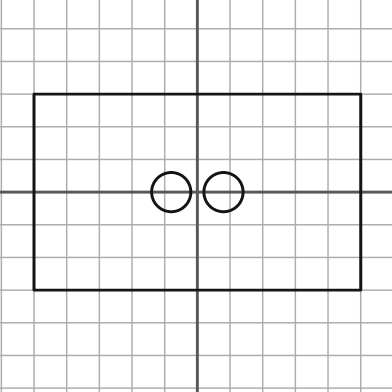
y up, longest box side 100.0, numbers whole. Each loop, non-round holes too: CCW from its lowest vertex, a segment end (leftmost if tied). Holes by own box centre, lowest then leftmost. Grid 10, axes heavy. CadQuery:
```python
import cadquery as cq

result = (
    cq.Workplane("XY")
    .moveTo(-50.0, -30.0)
    .lineTo(50.0, -30.0)
    .lineTo(50.0, 30.0)
    .lineTo(-50.0, 30.0)
    .close()
    .moveTo(-8.0, 0.0)
    .circle(6.0)
    .moveTo(8.0, 0.0)
    .circle(6.0)
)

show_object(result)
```